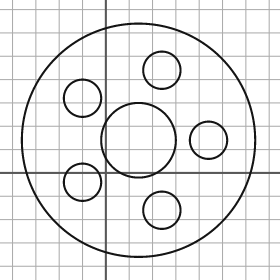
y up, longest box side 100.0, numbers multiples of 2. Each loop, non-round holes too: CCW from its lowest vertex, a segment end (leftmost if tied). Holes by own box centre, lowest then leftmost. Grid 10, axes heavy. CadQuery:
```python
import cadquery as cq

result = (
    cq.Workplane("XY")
    .moveTo(14.0, 14.0)
    .circle(50.0)
    .moveTo(24.0, -16.0)
    .circle(8.0)
    .moveTo(-10.0, -4.0)
    .circle(8.0)
    .moveTo(14.0, 14.0)
    .circle(16.0)
    .moveTo(44.0, 14.0)
    .circle(8.0)
    .moveTo(-10.0, 32.0)
    .circle(8.0)
    .moveTo(24.0, 44.0)
    .circle(8.0)
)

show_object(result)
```